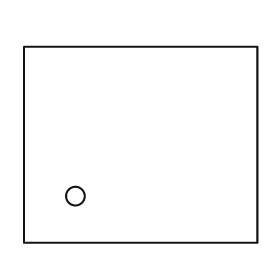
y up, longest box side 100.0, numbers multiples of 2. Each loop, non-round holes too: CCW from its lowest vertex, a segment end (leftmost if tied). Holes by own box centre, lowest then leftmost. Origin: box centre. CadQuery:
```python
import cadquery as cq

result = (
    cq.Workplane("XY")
    .moveTo(-50.0, -42.0)
    .lineTo(50.0, -42.0)
    .lineTo(50.0, 42.0)
    .lineTo(-50.0, 42.0)
    .close()
    .moveTo(-28.0, -22.0)
    .circle(4.0)
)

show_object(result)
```